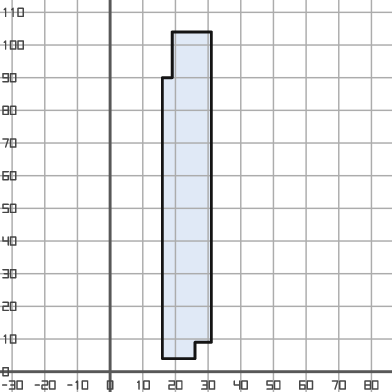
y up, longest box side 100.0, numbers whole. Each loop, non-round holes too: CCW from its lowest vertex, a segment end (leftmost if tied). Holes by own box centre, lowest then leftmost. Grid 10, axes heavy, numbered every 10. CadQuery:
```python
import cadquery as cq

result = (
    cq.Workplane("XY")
    .moveTo(16.0, 4.0)
    .lineTo(26.0, 4.0)
    .lineTo(26.0, 9.0)
    .lineTo(31.0, 9.0)
    .lineTo(31.0, 104.0)
    .lineTo(19.0, 104.0)
    .lineTo(19.0, 90.0)
    .lineTo(16.0, 90.0)
    .close()
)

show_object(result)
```